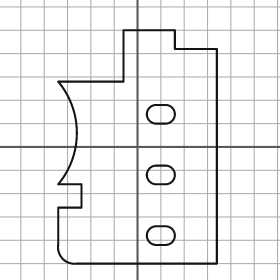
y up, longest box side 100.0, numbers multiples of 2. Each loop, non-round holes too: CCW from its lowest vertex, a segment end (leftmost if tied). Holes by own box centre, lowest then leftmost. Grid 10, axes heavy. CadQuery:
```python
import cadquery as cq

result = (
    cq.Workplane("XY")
    .moveTo(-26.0, -50.0)
    .lineTo(34.0, -50.0)
    .lineTo(34.0, 42.0)
    .lineTo(16.0, 42.0)
    .lineTo(16.0, 50.0)
    .lineTo(-6.0, 50.0)
    .lineTo(-6.0, 28.0)
    .lineTo(-34.0, 28.0)
    .threePointArc((-26.0, 6.0), (-34.0, -16.0))
    .lineTo(-24.0, -16.0)
    .lineTo(-24.0, -26.0)
    .lineTo(-34.0, -26.0)
    .lineTo(-34.0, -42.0)
    .threePointArc((-32.0, -48.0), (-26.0, -50.0))
    .close()
    .moveTo(8.0, -42.0)
    .lineTo(12.0, -42.0)
    .threePointArc((16.0, -38.0), (12.0, -34.0))
    .lineTo(8.0, -34.0)
    .threePointArc((4.0, -38.0), (8.0, -42.0))
    .close()
    .moveTo(8.0, -16.0)
    .lineTo(12.0, -16.0)
    .threePointArc((16.0, -12.0), (12.0, -8.0))
    .lineTo(8.0, -8.0)
    .threePointArc((4.0, -12.0), (8.0, -16.0))
    .close()
    .moveTo(8.0, 10.0)
    .lineTo(12.0, 10.0)
    .threePointArc((16.0, 14.0), (12.0, 18.0))
    .lineTo(8.0, 18.0)
    .threePointArc((4.0, 14.0), (8.0, 10.0))
    .close()
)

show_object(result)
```